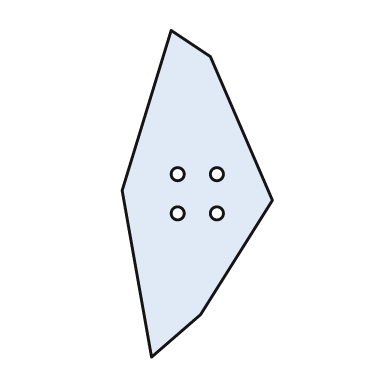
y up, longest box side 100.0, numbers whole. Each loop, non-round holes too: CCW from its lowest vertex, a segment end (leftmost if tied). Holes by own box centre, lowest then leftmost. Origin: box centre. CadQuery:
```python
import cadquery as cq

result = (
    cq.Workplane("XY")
    .moveTo(-14.0, -50.0)
    .lineTo(1.0, -37.0)
    .lineTo(23.0, -2.0)
    .lineTo(4.0, 42.0)
    .lineTo(-8.0, 50.0)
    .lineTo(-23.0, 1.0)
    .close()
    .moveTo(-6.0, -6.0)
    .circle(2.0)
    .moveTo(6.0, -6.0)
    .circle(2.0)
    .moveTo(-6.0, 6.0)
    .circle(2.0)
    .moveTo(6.0, 6.0)
    .circle(2.0)
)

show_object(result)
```